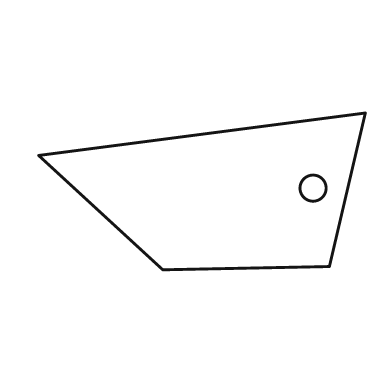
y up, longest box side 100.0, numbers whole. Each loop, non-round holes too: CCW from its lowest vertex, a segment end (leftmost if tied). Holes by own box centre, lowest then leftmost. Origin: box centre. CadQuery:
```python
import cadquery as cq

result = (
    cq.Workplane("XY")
    .moveTo(-12.0, -24.0)
    .lineTo(39.0, -23.0)
    .lineTo(50.0, 24.0)
    .lineTo(-50.0, 11.0)
    .close()
    .moveTo(34.0, 1.0)
    .circle(4.0)
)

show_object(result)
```